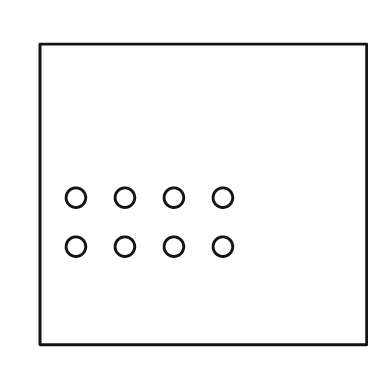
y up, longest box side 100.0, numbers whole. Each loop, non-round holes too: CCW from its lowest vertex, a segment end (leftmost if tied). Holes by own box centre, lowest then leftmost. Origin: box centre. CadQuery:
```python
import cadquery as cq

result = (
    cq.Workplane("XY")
    .moveTo(-50.0, -46.0)
    .lineTo(50.0, -46.0)
    .lineTo(50.0, 46.0)
    .lineTo(-50.0, 46.0)
    .close()
    .moveTo(-39.0, -16.0)
    .circle(3.0)
    .moveTo(-24.0, -16.0)
    .circle(3.0)
    .moveTo(-9.0, -16.0)
    .circle(3.0)
    .moveTo(6.0, -16.0)
    .circle(3.0)
    .moveTo(-39.0, -1.0)
    .circle(3.0)
    .moveTo(-24.0, -1.0)
    .circle(3.0)
    .moveTo(-9.0, -1.0)
    .circle(3.0)
    .moveTo(6.0, -1.0)
    .circle(3.0)
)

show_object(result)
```